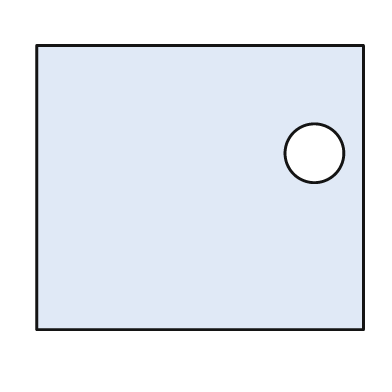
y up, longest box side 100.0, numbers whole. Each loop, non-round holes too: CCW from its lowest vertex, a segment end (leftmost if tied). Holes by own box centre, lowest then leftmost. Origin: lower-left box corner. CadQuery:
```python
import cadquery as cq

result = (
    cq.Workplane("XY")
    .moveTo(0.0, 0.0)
    .lineTo(100.0, 0.0)
    .lineTo(100.0, 87.0)
    .lineTo(0.0, 87.0)
    .close()
    .moveTo(85.0, 54.0)
    .circle(9.0)
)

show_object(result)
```